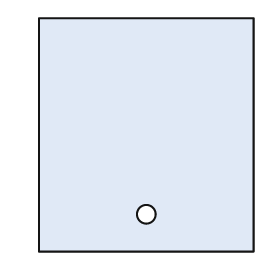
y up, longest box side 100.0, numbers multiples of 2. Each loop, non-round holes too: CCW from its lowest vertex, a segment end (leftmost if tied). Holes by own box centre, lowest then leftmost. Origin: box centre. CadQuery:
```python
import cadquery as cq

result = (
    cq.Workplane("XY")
    .moveTo(-46.0, -50.0)
    .lineTo(46.0, -50.0)
    .lineTo(46.0, 50.0)
    .lineTo(-46.0, 50.0)
    .close()
    .moveTo(0.0, -34.0)
    .circle(4.0)
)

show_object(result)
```